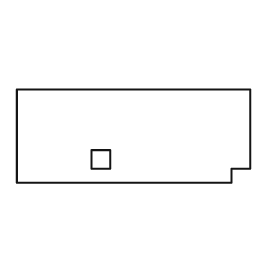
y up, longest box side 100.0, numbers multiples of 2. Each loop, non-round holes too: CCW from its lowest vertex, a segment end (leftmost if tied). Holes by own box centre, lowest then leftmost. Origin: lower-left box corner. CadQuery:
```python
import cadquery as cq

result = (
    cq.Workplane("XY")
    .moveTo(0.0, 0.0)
    .lineTo(92.0, 0.0)
    .lineTo(92.0, 6.0)
    .lineTo(100.0, 6.0)
    .lineTo(100.0, 40.0)
    .lineTo(0.0, 40.0)
    .close()
    .moveTo(32.0, 6.0)
    .lineTo(40.0, 6.0)
    .lineTo(40.0, 14.0)
    .lineTo(32.0, 14.0)
    .close()
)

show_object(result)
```